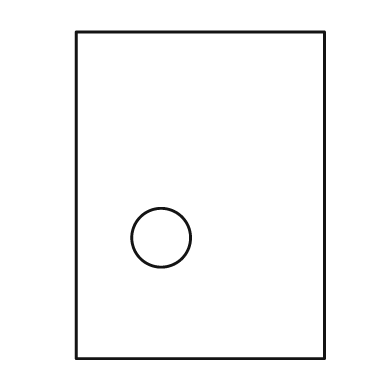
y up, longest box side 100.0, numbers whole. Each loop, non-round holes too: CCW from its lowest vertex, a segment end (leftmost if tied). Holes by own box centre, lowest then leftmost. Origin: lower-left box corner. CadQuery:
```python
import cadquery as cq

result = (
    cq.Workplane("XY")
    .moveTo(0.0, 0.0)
    .lineTo(76.0, 0.0)
    .lineTo(76.0, 100.0)
    .lineTo(0.0, 100.0)
    .close()
    .moveTo(26.0, 37.0)
    .circle(9.0)
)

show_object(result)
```